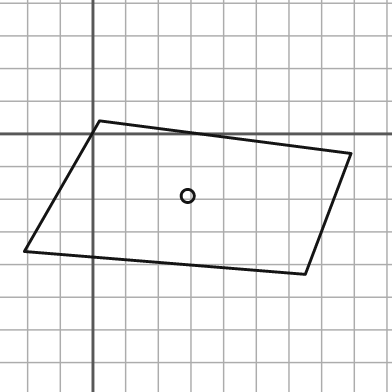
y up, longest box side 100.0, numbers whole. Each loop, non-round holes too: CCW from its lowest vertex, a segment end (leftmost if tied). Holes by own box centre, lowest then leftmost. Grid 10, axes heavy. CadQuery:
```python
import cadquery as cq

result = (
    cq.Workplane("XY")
    .moveTo(65.0, -43.0)
    .lineTo(79.0, -6.0)
    .lineTo(2.0, 4.0)
    .lineTo(-21.0, -36.0)
    .close()
    .moveTo(29.0, -19.0)
    .circle(2.0)
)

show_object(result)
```